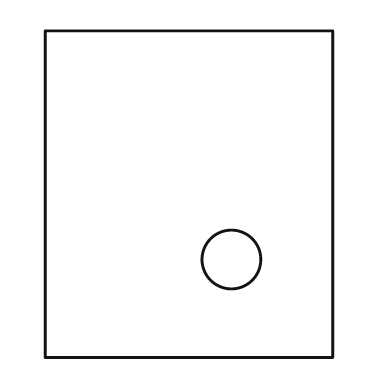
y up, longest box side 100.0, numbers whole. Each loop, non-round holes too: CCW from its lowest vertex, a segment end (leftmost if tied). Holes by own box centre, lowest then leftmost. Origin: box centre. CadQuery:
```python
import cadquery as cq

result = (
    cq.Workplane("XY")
    .moveTo(-44.0, -50.0)
    .lineTo(44.0, -50.0)
    .lineTo(44.0, 50.0)
    .lineTo(-44.0, 50.0)
    .close()
    .moveTo(13.0, -20.0)
    .circle(9.0)
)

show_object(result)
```